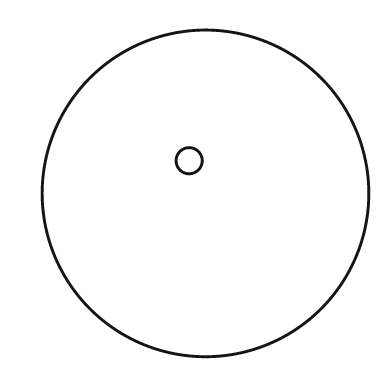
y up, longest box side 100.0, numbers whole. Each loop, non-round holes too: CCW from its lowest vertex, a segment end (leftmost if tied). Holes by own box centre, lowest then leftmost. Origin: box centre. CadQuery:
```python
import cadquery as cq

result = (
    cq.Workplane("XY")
    .moveTo(0.0, 0.0)
    .circle(50.0)
    .moveTo(-5.0, 10.0)
    .circle(4.0)
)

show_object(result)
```